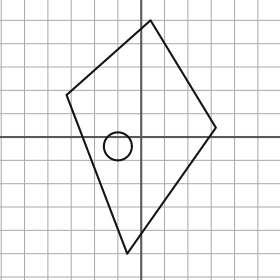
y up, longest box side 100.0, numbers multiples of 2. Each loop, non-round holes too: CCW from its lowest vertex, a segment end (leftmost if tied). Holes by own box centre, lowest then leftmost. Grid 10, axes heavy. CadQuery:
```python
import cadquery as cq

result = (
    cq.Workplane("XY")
    .moveTo(-6.0, -50.0)
    .lineTo(32.0, 4.0)
    .lineTo(4.0, 50.0)
    .lineTo(-32.0, 18.0)
    .close()
    .moveTo(-10.0, -4.0)
    .circle(6.0)
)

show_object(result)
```